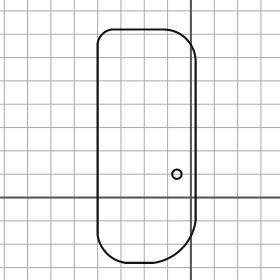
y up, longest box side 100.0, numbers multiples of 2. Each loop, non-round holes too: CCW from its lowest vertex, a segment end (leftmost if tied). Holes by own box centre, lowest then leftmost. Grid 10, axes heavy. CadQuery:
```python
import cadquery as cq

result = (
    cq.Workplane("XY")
    .moveTo(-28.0, -28.0)
    .lineTo(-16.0, -28.0)
    .threePointArc((-4.0, -22.0), (2.0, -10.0))
    .lineTo(2.0, 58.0)
    .threePointArc((-2.0, 68.0), (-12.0, 72.0))
    .lineTo(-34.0, 72.0)
    .threePointArc((-38.0, 70.0), (-40.0, 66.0))
    .lineTo(-40.0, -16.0)
    .threePointArc((-36.0, -24.0), (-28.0, -28.0))
    .close()
    .moveTo(-6.0, 10.0)
    .circle(2.0)
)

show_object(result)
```